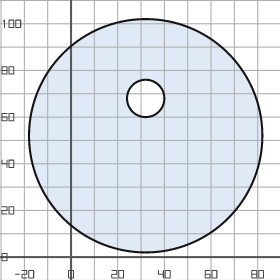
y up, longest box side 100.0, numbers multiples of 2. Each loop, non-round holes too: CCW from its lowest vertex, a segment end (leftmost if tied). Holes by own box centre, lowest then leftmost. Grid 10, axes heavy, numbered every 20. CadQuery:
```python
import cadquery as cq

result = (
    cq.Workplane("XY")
    .moveTo(32.0, 52.0)
    .circle(50.0)
    .moveTo(32.0, 68.0)
    .circle(8.0)
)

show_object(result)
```